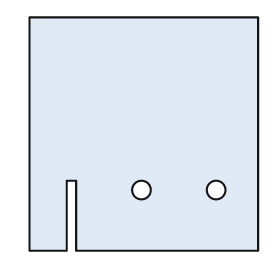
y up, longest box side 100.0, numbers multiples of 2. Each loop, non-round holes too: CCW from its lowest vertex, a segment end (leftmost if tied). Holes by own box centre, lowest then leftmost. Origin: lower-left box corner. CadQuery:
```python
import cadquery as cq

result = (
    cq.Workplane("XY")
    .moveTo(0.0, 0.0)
    .lineTo(16.0, 0.0)
    .lineTo(16.0, 30.0)
    .lineTo(20.0, 30.0)
    .lineTo(20.0, 0.0)
    .lineTo(98.0, 0.0)
    .lineTo(98.0, 100.0)
    .lineTo(0.0, 100.0)
    .close()
    .moveTo(48.0, 26.0)
    .circle(4.0)
    .moveTo(80.0, 26.0)
    .circle(4.0)
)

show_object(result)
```